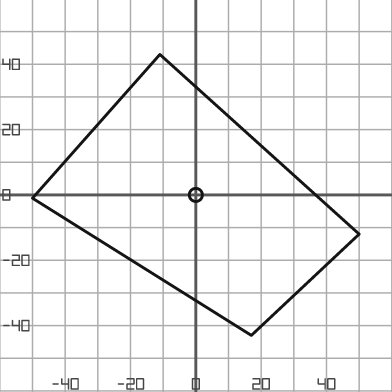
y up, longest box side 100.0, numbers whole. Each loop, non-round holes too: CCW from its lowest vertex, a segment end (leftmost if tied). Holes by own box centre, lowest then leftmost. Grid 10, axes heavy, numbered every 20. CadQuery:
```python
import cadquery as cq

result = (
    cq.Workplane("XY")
    .moveTo(17.0, -43.0)
    .lineTo(50.0, -12.0)
    .lineTo(-11.0, 43.0)
    .lineTo(-50.0, -1.0)
    .close()
    .moveTo(0.0, 0.0)
    .circle(2.0)
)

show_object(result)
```